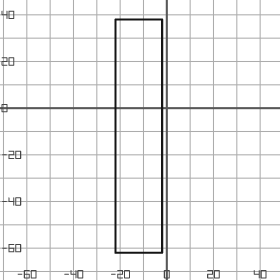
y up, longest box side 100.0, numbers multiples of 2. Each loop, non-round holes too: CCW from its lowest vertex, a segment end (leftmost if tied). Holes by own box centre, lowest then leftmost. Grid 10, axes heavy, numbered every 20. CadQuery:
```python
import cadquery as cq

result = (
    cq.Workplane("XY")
    .moveTo(-22.0, -62.0)
    .lineTo(-2.0, -62.0)
    .lineTo(-2.0, 38.0)
    .lineTo(-22.0, 38.0)
    .close()
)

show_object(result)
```